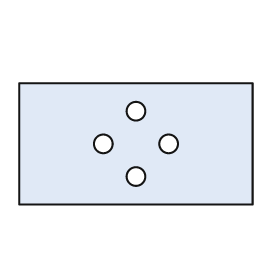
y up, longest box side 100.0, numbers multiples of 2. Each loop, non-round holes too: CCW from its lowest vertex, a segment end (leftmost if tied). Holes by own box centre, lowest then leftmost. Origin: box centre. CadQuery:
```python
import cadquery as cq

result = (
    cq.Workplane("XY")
    .moveTo(-50.0, -26.0)
    .lineTo(50.0, -26.0)
    .lineTo(50.0, 26.0)
    .lineTo(-50.0, 26.0)
    .close()
    .moveTo(0.0, -14.0)
    .circle(4.0)
    .moveTo(-14.0, 0.0)
    .circle(4.0)
    .moveTo(14.0, 0.0)
    .circle(4.0)
    .moveTo(0.0, 14.0)
    .circle(4.0)
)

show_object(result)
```